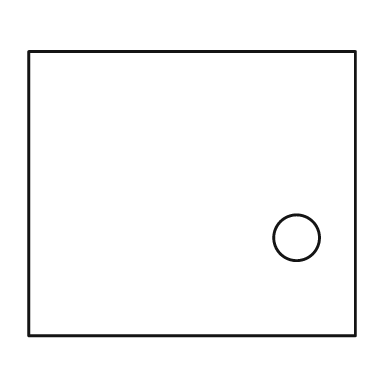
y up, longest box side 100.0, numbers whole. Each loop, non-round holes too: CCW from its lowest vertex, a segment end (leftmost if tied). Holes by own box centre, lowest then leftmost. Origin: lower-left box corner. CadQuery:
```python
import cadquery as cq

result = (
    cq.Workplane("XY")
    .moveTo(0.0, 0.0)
    .lineTo(100.0, 0.0)
    .lineTo(100.0, 87.0)
    .lineTo(0.0, 87.0)
    .close()
    .moveTo(82.0, 30.0)
    .circle(7.0)
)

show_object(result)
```